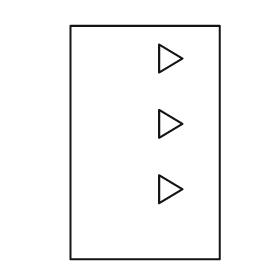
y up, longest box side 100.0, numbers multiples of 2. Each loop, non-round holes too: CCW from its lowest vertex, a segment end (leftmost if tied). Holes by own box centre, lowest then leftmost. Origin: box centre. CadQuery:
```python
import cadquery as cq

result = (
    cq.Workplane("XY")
    .moveTo(-32.0, -50.0)
    .lineTo(32.0, -50.0)
    .lineTo(32.0, 50.0)
    .lineTo(-32.0, 50.0)
    .close()
    .moveTo(6.0, -26.0)
    .lineTo(16.0, -20.0)
    .lineTo(6.0, -14.0)
    .close()
    .moveTo(6.0, 2.0)
    .lineTo(16.0, 8.0)
    .lineTo(6.0, 14.0)
    .close()
    .moveTo(6.0, 30.0)
    .lineTo(16.0, 36.0)
    .lineTo(6.0, 42.0)
    .close()
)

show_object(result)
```